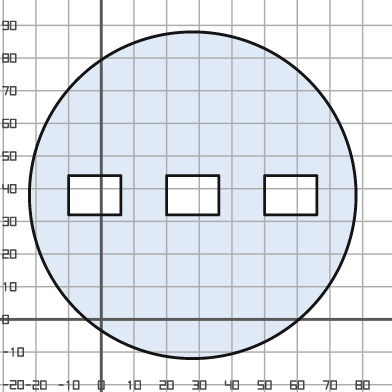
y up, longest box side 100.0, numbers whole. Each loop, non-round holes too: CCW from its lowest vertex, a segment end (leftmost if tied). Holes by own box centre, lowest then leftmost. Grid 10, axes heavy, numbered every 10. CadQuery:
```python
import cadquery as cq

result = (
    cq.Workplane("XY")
    .moveTo(28.0, 38.0)
    .circle(50.0)
    .moveTo(-10.0, 32.0)
    .lineTo(6.0, 32.0)
    .lineTo(6.0, 44.0)
    .lineTo(-10.0, 44.0)
    .close()
    .moveTo(20.0, 32.0)
    .lineTo(36.0, 32.0)
    .lineTo(36.0, 44.0)
    .lineTo(20.0, 44.0)
    .close()
    .moveTo(50.0, 32.0)
    .lineTo(66.0, 32.0)
    .lineTo(66.0, 44.0)
    .lineTo(50.0, 44.0)
    .close()
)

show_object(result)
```